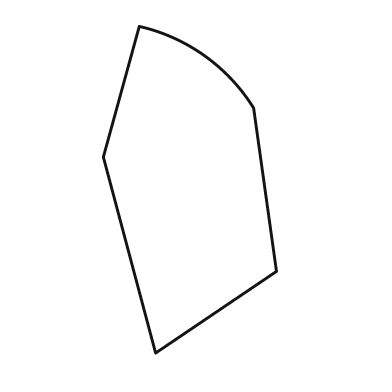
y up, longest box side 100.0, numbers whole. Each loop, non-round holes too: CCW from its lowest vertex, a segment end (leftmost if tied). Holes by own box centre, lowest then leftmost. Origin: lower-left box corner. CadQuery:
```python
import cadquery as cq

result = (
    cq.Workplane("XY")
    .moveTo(16.0, 0.0)
    .lineTo(53.0, 25.0)
    .lineTo(46.0, 75.0)
    .threePointArc((31.0, 91.0), (11.0, 100.0))
    .lineTo(0.0, 60.0)
    .close()
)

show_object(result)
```